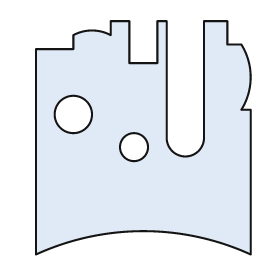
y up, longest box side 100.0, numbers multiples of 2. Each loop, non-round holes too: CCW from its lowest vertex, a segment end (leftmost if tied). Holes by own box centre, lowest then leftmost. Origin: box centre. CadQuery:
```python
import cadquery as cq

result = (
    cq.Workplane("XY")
    .moveTo(-46.0, -50.0)
    .threePointArc((0.0, -40.0), (46.0, -50.0))
    .lineTo(46.0, 12.0)
    .lineTo(42.0, 12.0)
    .threePointArc((46.0, 26.0), (42.0, 40.0))
    .lineTo(36.0, 40.0)
    .lineTo(36.0, 50.0)
    .lineTo(26.0, 50.0)
    .lineTo(26.0, 0.0)
    .threePointArc((18.0, -8.0), (10.0, 0.0))
    .lineTo(10.0, 50.0)
    .lineTo(6.0, 50.0)
    .lineTo(6.0, 32.0)
    .lineTo(-6.0, 32.0)
    .lineTo(-6.0, 50.0)
    .lineTo(-14.0, 50.0)
    .lineTo(-14.0, 44.0)
    .threePointArc((-22.0, 46.0), (-30.0, 44.0))
    .lineTo(-30.0, 38.0)
    .lineTo(-46.0, 38.0)
    .close()
    .moveTo(-4.0, -4.0)
    .circle(6.0)
    .moveTo(-30.0, 10.0)
    .circle(8.0)
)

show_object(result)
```